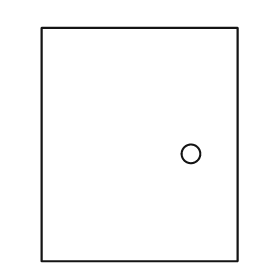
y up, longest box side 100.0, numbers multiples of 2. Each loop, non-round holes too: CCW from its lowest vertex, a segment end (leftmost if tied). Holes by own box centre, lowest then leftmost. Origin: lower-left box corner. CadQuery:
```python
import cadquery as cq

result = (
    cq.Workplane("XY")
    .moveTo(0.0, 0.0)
    .lineTo(84.0, 0.0)
    .lineTo(84.0, 100.0)
    .lineTo(0.0, 100.0)
    .close()
    .moveTo(64.0, 46.0)
    .circle(4.0)
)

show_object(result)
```